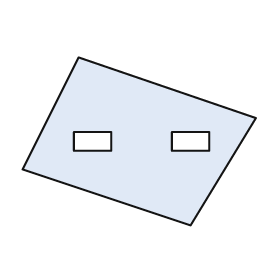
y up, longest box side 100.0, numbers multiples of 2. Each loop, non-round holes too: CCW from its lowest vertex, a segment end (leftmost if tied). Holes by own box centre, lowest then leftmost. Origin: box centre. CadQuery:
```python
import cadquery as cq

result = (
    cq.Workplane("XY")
    .moveTo(22.0, -36.0)
    .lineTo(50.0, 10.0)
    .lineTo(-26.0, 36.0)
    .lineTo(-50.0, -12.0)
    .close()
    .moveTo(-28.0, -4.0)
    .lineTo(-12.0, -4.0)
    .lineTo(-12.0, 4.0)
    .lineTo(-28.0, 4.0)
    .close()
    .moveTo(14.0, -4.0)
    .lineTo(30.0, -4.0)
    .lineTo(30.0, 4.0)
    .lineTo(14.0, 4.0)
    .close()
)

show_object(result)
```